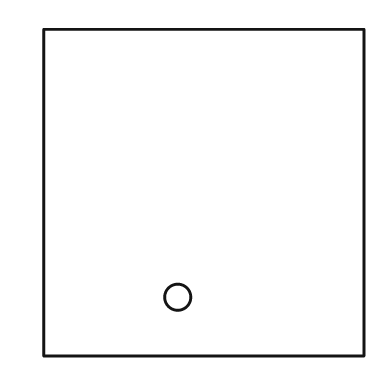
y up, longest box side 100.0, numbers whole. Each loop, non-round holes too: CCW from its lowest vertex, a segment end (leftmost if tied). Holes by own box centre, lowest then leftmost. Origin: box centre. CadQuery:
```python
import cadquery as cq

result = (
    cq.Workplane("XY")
    .moveTo(-49.0, -50.0)
    .lineTo(49.0, -50.0)
    .lineTo(49.0, 50.0)
    .lineTo(-49.0, 50.0)
    .close()
    .moveTo(-8.0, -32.0)
    .circle(4.0)
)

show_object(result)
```